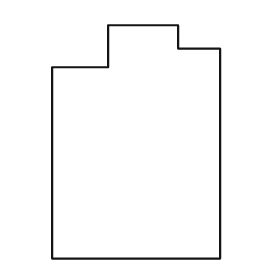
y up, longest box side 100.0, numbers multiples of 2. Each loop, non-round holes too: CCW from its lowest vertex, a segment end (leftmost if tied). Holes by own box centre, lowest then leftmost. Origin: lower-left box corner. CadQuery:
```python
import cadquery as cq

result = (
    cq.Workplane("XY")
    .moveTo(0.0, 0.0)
    .lineTo(72.0, 0.0)
    .lineTo(72.0, 90.0)
    .lineTo(54.0, 90.0)
    .lineTo(54.0, 100.0)
    .lineTo(24.0, 100.0)
    .lineTo(24.0, 82.0)
    .lineTo(0.0, 82.0)
    .close()
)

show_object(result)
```